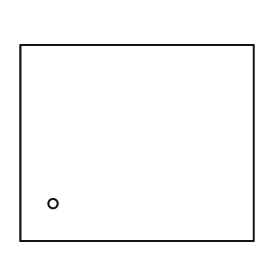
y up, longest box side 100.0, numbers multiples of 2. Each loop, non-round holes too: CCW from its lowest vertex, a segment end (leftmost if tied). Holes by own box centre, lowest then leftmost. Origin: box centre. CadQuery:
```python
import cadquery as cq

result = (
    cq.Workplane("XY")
    .moveTo(-50.0, -42.0)
    .lineTo(50.0, -42.0)
    .lineTo(50.0, 42.0)
    .lineTo(-50.0, 42.0)
    .close()
    .moveTo(-36.0, -26.0)
    .circle(2.0)
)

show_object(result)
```